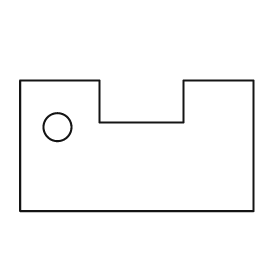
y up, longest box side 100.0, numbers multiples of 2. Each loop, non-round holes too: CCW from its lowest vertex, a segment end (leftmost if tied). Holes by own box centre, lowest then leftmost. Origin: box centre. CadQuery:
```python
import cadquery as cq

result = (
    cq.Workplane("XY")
    .moveTo(-50.0, -28.0)
    .lineTo(50.0, -28.0)
    .lineTo(50.0, 28.0)
    .lineTo(20.0, 28.0)
    .lineTo(20.0, 10.0)
    .lineTo(-16.0, 10.0)
    .lineTo(-16.0, 28.0)
    .lineTo(-50.0, 28.0)
    .close()
    .moveTo(-34.0, 8.0)
    .circle(6.0)
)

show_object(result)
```